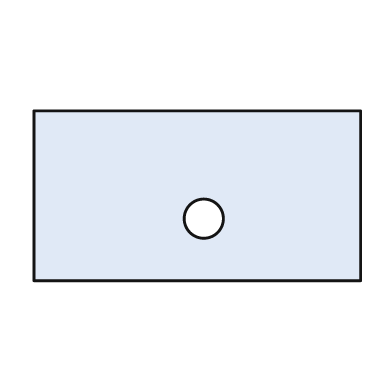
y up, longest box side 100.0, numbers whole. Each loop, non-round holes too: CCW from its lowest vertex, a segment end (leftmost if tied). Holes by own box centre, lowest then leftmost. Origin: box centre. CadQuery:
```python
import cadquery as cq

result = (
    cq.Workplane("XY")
    .moveTo(-50.0, -26.0)
    .lineTo(50.0, -26.0)
    .lineTo(50.0, 26.0)
    .lineTo(-50.0, 26.0)
    .close()
    .moveTo(2.0, -7.0)
    .circle(6.0)
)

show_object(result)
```